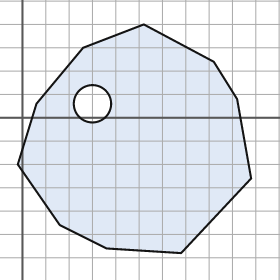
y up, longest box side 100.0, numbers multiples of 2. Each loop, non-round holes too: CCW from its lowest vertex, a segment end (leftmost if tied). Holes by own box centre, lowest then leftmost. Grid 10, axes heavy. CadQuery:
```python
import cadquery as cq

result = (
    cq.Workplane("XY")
    .moveTo(68.0, -58.0)
    .lineTo(98.0, -26.0)
    .lineTo(92.0, 8.0)
    .lineTo(82.0, 24.0)
    .lineTo(52.0, 40.0)
    .lineTo(26.0, 30.0)
    .lineTo(6.0, 6.0)
    .lineTo(-2.0, -20.0)
    .lineTo(16.0, -46.0)
    .lineTo(36.0, -56.0)
    .close()
    .moveTo(30.0, 6.0)
    .circle(8.0)
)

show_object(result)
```